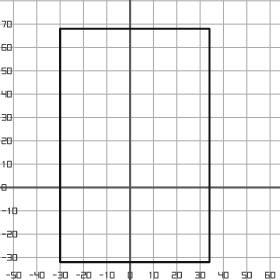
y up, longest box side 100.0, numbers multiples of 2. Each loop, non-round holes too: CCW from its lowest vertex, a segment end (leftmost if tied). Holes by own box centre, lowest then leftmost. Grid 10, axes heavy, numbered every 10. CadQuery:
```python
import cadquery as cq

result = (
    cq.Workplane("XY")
    .moveTo(-30.0, -32.0)
    .lineTo(34.0, -32.0)
    .lineTo(34.0, 68.0)
    .lineTo(-30.0, 68.0)
    .close()
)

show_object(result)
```